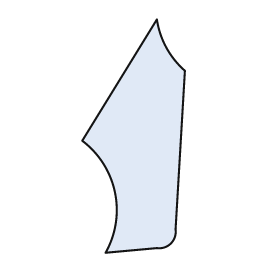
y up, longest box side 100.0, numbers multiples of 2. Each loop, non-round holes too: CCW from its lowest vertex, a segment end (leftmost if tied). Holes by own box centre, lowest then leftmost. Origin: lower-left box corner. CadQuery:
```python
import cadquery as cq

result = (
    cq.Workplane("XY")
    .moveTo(10.0, 0.0)
    .lineTo(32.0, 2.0)
    .threePointArc((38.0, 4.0), (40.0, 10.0))
    .lineTo(44.0, 78.0)
    .threePointArc((36.0, 88.0), (32.0, 100.0))
    .lineTo(0.0, 48.0)
    .threePointArc((14.0, 26.0), (10.0, 0.0))
    .close()
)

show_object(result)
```